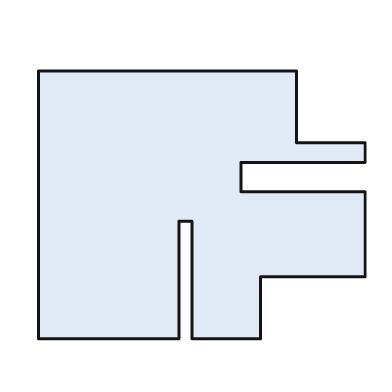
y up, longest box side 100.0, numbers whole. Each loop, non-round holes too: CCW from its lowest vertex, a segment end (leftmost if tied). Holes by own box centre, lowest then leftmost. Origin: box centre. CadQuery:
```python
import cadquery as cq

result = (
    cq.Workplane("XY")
    .moveTo(-50.0, -41.0)
    .lineTo(-7.0, -41.0)
    .lineTo(-7.0, -5.0)
    .lineTo(-3.0, -5.0)
    .lineTo(-3.0, -41.0)
    .lineTo(18.0, -41.0)
    .lineTo(18.0, -22.0)
    .lineTo(50.0, -22.0)
    .lineTo(50.0, 4.0)
    .lineTo(12.0, 4.0)
    .lineTo(12.0, 13.0)
    .lineTo(50.0, 13.0)
    .lineTo(50.0, 19.0)
    .lineTo(29.0, 19.0)
    .lineTo(29.0, 41.0)
    .lineTo(-50.0, 41.0)
    .close()
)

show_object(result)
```